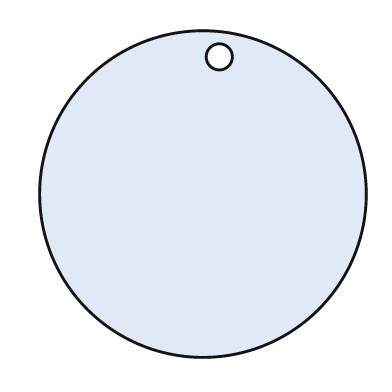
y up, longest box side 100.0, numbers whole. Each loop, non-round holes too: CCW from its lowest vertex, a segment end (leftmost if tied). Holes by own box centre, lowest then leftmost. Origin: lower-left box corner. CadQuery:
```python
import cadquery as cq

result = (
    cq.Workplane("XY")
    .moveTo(50.0, 50.0)
    .circle(50.0)
    .moveTo(55.0, 92.0)
    .circle(4.0)
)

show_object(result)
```